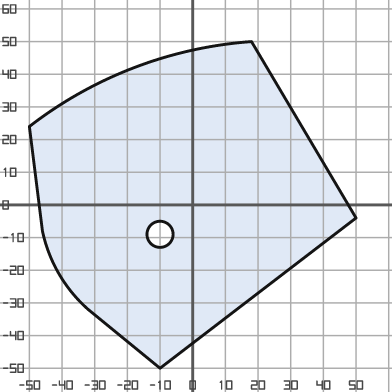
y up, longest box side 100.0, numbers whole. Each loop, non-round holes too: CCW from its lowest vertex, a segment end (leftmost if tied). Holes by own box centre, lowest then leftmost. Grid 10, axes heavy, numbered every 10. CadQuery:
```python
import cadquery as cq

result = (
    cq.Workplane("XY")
    .moveTo(-10.0, -50.0)
    .lineTo(50.0, -4.0)
    .lineTo(18.0, 50.0)
    .threePointArc((-18.0, 42.0), (-50.0, 24.0))
    .lineTo(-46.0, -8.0)
    .threePointArc((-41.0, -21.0), (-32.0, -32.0))
    .close()
    .moveTo(-10.0, -9.0)
    .circle(4.0)
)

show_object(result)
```